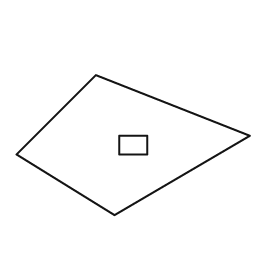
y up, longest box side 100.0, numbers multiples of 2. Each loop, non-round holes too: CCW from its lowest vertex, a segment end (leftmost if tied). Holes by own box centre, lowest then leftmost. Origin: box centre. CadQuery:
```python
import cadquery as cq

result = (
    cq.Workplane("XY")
    .moveTo(-8.0, -30.0)
    .lineTo(50.0, 4.0)
    .lineTo(-16.0, 30.0)
    .lineTo(-50.0, -4.0)
    .close()
    .moveTo(-6.0, -4.0)
    .lineTo(6.0, -4.0)
    .lineTo(6.0, 4.0)
    .lineTo(-6.0, 4.0)
    .close()
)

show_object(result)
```